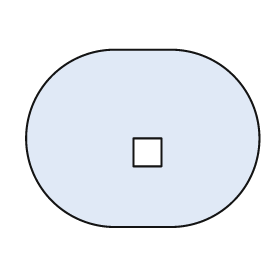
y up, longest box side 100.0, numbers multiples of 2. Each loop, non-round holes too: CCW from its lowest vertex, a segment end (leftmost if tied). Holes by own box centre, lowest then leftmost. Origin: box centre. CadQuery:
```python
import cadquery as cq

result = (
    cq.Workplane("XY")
    .moveTo(-12.0, -38.0)
    .lineTo(12.0, -38.0)
    .threePointArc((50.0, 0.0), (12.0, 38.0))
    .lineTo(-12.0, 38.0)
    .threePointArc((-50.0, 0.0), (-12.0, -38.0))
    .close()
    .moveTo(-4.0, -12.0)
    .lineTo(8.0, -12.0)
    .lineTo(8.0, 0.0)
    .lineTo(-4.0, 0.0)
    .close()
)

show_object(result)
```